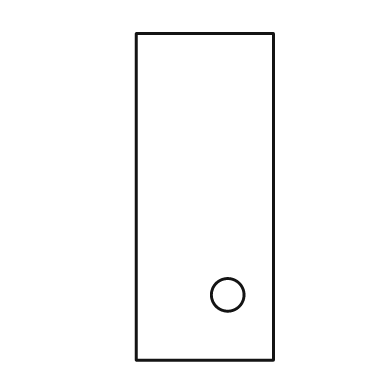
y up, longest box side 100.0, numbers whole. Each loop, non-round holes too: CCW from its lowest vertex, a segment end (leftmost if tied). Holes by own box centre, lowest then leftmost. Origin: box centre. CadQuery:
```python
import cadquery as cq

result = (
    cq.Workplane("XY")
    .moveTo(-21.0, -50.0)
    .lineTo(21.0, -50.0)
    .lineTo(21.0, 50.0)
    .lineTo(-21.0, 50.0)
    .close()
    .moveTo(7.0, -30.0)
    .circle(5.0)
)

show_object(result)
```